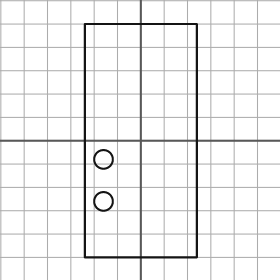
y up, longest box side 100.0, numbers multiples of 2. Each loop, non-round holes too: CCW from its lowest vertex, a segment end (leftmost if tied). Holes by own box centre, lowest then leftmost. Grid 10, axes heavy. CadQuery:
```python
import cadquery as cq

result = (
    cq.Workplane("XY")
    .moveTo(-24.0, -50.0)
    .lineTo(24.0, -50.0)
    .lineTo(24.0, 50.0)
    .lineTo(-24.0, 50.0)
    .close()
    .moveTo(-16.0, -26.0)
    .circle(4.0)
    .moveTo(-16.0, -8.0)
    .circle(4.0)
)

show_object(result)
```